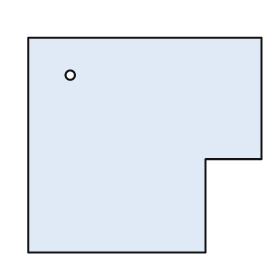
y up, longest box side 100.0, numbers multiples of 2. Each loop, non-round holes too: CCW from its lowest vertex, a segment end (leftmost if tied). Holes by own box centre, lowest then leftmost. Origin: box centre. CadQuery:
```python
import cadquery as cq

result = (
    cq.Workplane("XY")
    .moveTo(-50.0, -46.0)
    .lineTo(26.0, -46.0)
    .lineTo(26.0, -6.0)
    .lineTo(50.0, -6.0)
    .lineTo(50.0, 46.0)
    .lineTo(-50.0, 46.0)
    .close()
    .moveTo(-32.0, 30.0)
    .circle(2.0)
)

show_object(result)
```